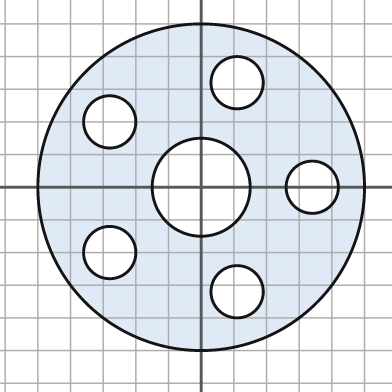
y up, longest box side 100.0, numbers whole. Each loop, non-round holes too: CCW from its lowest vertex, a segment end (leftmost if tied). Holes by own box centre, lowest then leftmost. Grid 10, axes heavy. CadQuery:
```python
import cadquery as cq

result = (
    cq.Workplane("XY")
    .moveTo(0.0, 0.0)
    .circle(50.0)
    .moveTo(11.0, -32.0)
    .circle(8.0)
    .moveTo(-28.0, -20.0)
    .circle(8.0)
    .moveTo(0.0, 0.0)
    .circle(15.0)
    .moveTo(34.0, 0.0)
    .circle(8.0)
    .moveTo(-28.0, 20.0)
    .circle(8.0)
    .moveTo(11.0, 32.0)
    .circle(8.0)
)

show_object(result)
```